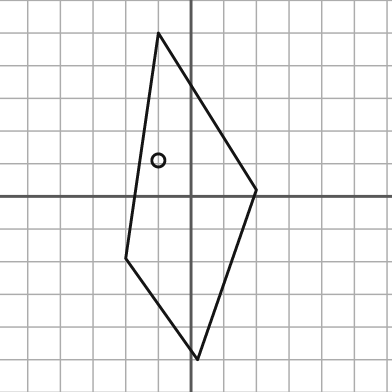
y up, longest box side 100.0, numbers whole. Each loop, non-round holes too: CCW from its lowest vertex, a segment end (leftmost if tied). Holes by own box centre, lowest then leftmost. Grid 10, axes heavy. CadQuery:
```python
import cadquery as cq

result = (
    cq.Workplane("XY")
    .moveTo(2.0, -50.0)
    .lineTo(20.0, 2.0)
    .lineTo(-10.0, 50.0)
    .lineTo(-20.0, -19.0)
    .close()
    .moveTo(-10.0, 11.0)
    .circle(2.0)
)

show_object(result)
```